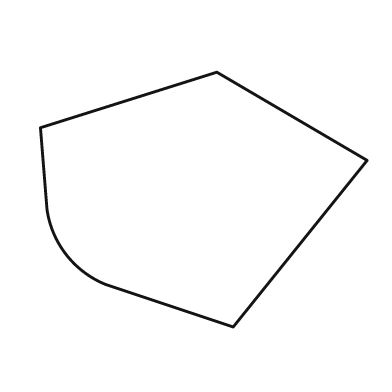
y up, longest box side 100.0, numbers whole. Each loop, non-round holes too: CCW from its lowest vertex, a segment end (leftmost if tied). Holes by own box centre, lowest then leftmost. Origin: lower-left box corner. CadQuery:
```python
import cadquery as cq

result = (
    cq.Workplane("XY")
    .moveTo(59.0, 0.0)
    .lineTo(100.0, 51.0)
    .lineTo(54.0, 78.0)
    .lineTo(0.0, 61.0)
    .lineTo(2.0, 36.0)
    .threePointArc((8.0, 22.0), (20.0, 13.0))
    .close()
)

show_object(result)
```